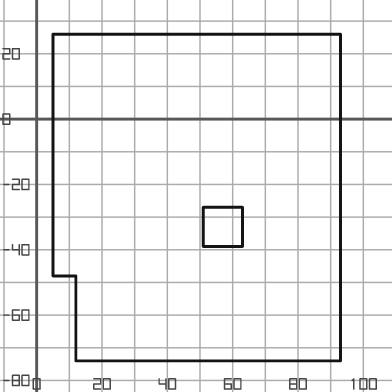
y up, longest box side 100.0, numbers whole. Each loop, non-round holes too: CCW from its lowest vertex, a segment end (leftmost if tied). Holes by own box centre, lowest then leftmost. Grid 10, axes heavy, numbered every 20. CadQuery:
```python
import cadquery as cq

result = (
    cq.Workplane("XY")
    .moveTo(12.0, -74.0)
    .lineTo(93.0, -74.0)
    .lineTo(93.0, 26.0)
    .lineTo(5.0, 26.0)
    .lineTo(5.0, -48.0)
    .lineTo(12.0, -48.0)
    .close()
    .moveTo(51.0, -39.0)
    .lineTo(63.0, -39.0)
    .lineTo(63.0, -27.0)
    .lineTo(51.0, -27.0)
    .close()
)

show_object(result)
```